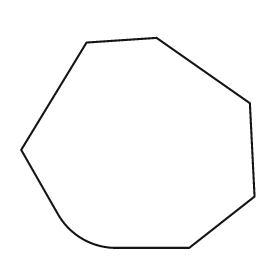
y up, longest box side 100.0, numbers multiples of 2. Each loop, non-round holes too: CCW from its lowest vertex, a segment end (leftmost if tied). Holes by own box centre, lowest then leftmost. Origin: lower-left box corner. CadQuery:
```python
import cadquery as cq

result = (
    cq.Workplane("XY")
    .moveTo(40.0, 0.0)
    .lineTo(72.0, 0.0)
    .lineTo(100.0, 22.0)
    .lineTo(98.0, 62.0)
    .lineTo(58.0, 90.0)
    .lineTo(28.0, 88.0)
    .lineTo(0.0, 42.0)
    .lineTo(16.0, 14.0)
    .threePointArc((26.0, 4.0), (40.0, 0.0))
    .close()
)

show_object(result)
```